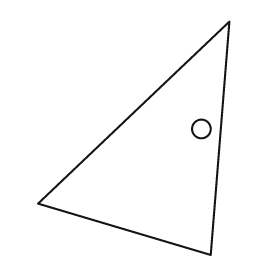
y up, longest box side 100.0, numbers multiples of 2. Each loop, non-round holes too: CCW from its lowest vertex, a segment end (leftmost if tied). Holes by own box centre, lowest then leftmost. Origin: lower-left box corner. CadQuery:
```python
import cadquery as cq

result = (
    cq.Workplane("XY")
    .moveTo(74.0, 0.0)
    .lineTo(82.0, 100.0)
    .lineTo(0.0, 22.0)
    .close()
    .moveTo(70.0, 54.0)
    .circle(4.0)
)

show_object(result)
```